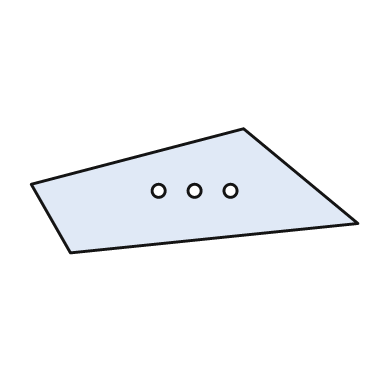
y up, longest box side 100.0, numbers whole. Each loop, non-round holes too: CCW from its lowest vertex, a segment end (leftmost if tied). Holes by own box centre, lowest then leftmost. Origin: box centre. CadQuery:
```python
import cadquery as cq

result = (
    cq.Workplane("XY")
    .moveTo(-38.0, -19.0)
    .lineTo(50.0, -10.0)
    .lineTo(15.0, 19.0)
    .lineTo(-50.0, 2.0)
    .close()
    .moveTo(-11.0, 0.0)
    .circle(2.0)
    .moveTo(0.0, 0.0)
    .circle(2.0)
    .moveTo(11.0, 0.0)
    .circle(2.0)
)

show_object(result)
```